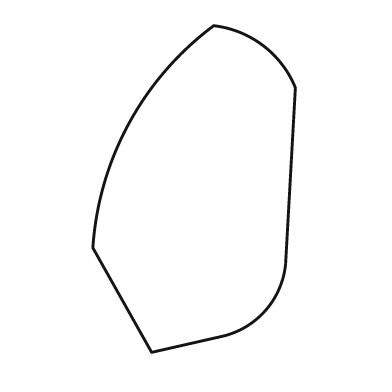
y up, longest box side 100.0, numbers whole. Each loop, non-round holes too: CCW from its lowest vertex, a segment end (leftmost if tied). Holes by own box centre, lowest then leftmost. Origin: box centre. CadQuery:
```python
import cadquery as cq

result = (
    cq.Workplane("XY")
    .moveTo(-13.0, -50.0)
    .lineTo(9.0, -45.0)
    .threePointArc((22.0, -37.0), (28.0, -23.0))
    .lineTo(31.0, 31.0)
    .threePointArc((21.0, 44.0), (6.0, 50.0))
    .threePointArc((-20.0, 20.0), (-31.0, -18.0))
    .close()
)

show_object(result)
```